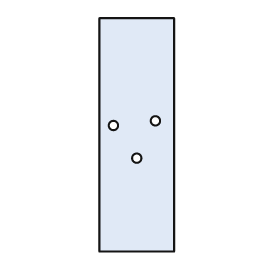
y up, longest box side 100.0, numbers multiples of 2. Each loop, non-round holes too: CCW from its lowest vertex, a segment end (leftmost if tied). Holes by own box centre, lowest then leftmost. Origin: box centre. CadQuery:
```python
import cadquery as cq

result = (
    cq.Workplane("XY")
    .moveTo(-16.0, -50.0)
    .lineTo(16.0, -50.0)
    .lineTo(16.0, 50.0)
    .lineTo(-16.0, 50.0)
    .close()
    .moveTo(0.0, -10.0)
    .circle(2.0)
    .moveTo(-10.0, 4.0)
    .circle(2.0)
    .moveTo(8.0, 6.0)
    .circle(2.0)
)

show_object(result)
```